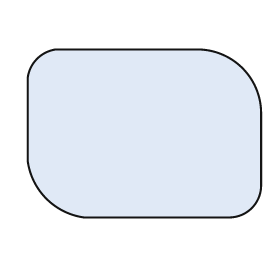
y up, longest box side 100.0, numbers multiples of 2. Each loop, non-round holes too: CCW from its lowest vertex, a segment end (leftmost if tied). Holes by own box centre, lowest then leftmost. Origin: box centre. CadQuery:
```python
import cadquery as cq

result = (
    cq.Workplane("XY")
    .moveTo(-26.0, -36.0)
    .lineTo(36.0, -36.0)
    .threePointArc((46.0, -32.0), (50.0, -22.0))
    .lineTo(50.0, 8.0)
    .threePointArc((42.0, 28.0), (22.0, 36.0))
    .lineTo(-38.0, 36.0)
    .threePointArc((-46.0, 32.0), (-50.0, 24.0))
    .lineTo(-50.0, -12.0)
    .threePointArc((-42.0, -28.0), (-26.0, -36.0))
    .close()
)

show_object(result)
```